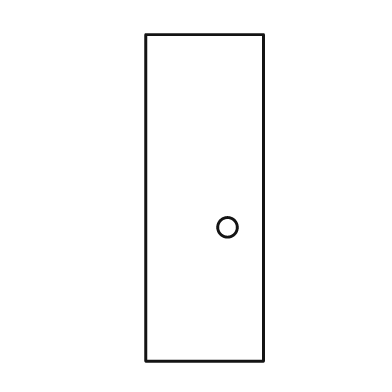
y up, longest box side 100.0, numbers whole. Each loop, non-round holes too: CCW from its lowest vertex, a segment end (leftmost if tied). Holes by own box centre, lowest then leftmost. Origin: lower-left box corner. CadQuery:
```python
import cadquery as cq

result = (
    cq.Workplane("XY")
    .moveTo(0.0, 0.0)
    .lineTo(36.0, 0.0)
    .lineTo(36.0, 100.0)
    .lineTo(0.0, 100.0)
    .close()
    .moveTo(25.0, 41.0)
    .circle(3.0)
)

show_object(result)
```